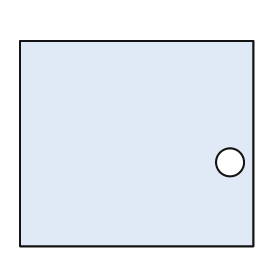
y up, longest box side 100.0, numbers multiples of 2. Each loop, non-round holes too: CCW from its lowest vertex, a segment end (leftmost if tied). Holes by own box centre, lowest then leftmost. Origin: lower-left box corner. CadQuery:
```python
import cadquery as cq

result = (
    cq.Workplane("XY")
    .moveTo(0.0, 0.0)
    .lineTo(100.0, 0.0)
    .lineTo(100.0, 88.0)
    .lineTo(0.0, 88.0)
    .close()
    .moveTo(90.0, 36.0)
    .circle(6.0)
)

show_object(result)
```